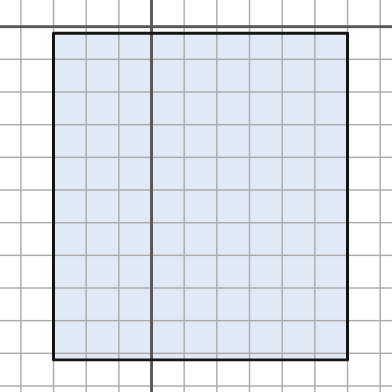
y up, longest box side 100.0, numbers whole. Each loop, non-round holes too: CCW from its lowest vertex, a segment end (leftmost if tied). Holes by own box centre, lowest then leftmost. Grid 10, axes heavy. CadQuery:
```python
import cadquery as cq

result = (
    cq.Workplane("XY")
    .moveTo(-30.0, -102.0)
    .lineTo(60.0, -102.0)
    .lineTo(60.0, -2.0)
    .lineTo(-30.0, -2.0)
    .close()
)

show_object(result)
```